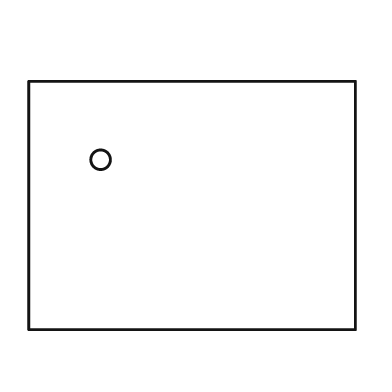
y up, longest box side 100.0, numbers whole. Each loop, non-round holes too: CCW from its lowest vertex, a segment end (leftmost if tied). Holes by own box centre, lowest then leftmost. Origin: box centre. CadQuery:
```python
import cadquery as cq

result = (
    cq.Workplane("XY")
    .moveTo(-50.0, -38.0)
    .lineTo(50.0, -38.0)
    .lineTo(50.0, 38.0)
    .lineTo(-50.0, 38.0)
    .close()
    .moveTo(-28.0, 14.0)
    .circle(3.0)
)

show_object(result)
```